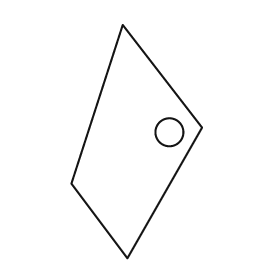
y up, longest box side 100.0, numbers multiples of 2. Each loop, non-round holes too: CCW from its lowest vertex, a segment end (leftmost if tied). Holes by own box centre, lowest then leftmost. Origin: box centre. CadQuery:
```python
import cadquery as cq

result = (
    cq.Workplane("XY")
    .moveTo(-4.0, -50.0)
    .lineTo(28.0, 6.0)
    .lineTo(-6.0, 50.0)
    .lineTo(-28.0, -18.0)
    .close()
    .moveTo(14.0, 4.0)
    .circle(6.0)
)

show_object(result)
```